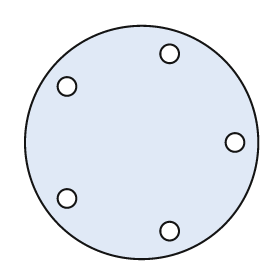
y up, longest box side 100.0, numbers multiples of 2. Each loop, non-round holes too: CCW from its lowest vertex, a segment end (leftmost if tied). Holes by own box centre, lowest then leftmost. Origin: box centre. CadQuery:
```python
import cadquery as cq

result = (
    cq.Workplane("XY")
    .moveTo(0.0, 0.0)
    .circle(50.0)
    .moveTo(12.0, -38.0)
    .circle(4.0)
    .moveTo(-32.0, -24.0)
    .circle(4.0)
    .moveTo(40.0, 0.0)
    .circle(4.0)
    .moveTo(-32.0, 24.0)
    .circle(4.0)
    .moveTo(12.0, 38.0)
    .circle(4.0)
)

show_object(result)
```